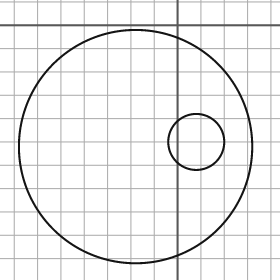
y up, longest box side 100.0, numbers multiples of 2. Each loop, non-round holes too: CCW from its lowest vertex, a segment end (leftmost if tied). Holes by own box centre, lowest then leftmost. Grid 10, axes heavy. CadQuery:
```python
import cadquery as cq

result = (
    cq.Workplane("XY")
    .moveTo(-18.0, -52.0)
    .circle(50.0)
    .moveTo(8.0, -50.0)
    .circle(12.0)
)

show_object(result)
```